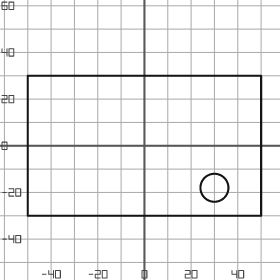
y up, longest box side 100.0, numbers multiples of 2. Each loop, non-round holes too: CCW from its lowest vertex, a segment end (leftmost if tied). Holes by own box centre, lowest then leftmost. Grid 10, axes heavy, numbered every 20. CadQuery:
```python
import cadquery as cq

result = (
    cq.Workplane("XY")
    .moveTo(-50.0, -30.0)
    .lineTo(50.0, -30.0)
    .lineTo(50.0, 30.0)
    .lineTo(-50.0, 30.0)
    .close()
    .moveTo(30.0, -18.0)
    .circle(6.0)
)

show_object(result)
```